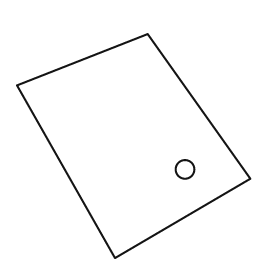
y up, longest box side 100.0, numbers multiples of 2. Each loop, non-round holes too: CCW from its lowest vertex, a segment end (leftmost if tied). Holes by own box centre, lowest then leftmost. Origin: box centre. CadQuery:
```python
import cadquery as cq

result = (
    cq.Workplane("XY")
    .moveTo(-8.0, -48.0)
    .lineTo(50.0, -14.0)
    .lineTo(6.0, 48.0)
    .lineTo(-50.0, 26.0)
    .close()
    .moveTo(22.0, -10.0)
    .circle(4.0)
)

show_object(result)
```